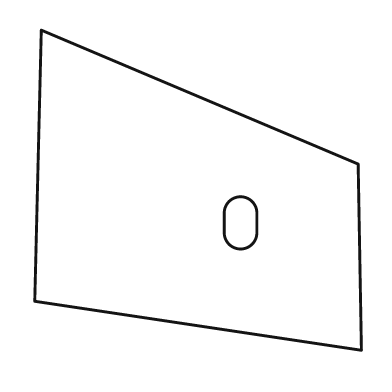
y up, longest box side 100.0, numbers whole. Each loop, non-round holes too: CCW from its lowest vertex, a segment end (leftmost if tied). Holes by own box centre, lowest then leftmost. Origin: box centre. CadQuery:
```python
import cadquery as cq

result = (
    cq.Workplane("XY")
    .moveTo(50.0, -49.0)
    .lineTo(49.0, 8.0)
    .lineTo(-48.0, 49.0)
    .lineTo(-50.0, -34.0)
    .close()
    .moveTo(8.0, -13.0)
    .threePointArc((13.0, -18.0), (18.0, -13.0))
    .lineTo(18.0, -7.0)
    .threePointArc((13.0, -2.0), (8.0, -7.0))
    .close()
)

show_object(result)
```